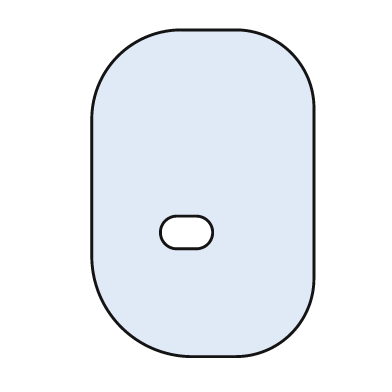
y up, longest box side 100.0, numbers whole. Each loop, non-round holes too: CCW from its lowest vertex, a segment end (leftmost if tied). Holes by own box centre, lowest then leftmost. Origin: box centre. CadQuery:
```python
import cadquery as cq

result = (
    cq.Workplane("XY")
    .moveTo(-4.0, -50.0)
    .lineTo(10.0, -50.0)
    .threePointArc((27.0, -43.0), (34.0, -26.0))
    .lineTo(34.0, 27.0)
    .threePointArc((27.0, 43.0), (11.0, 50.0))
    .lineTo(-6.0, 50.0)
    .threePointArc((-26.0, 42.0), (-34.0, 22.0))
    .lineTo(-34.0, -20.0)
    .threePointArc((-25.0, -41.0), (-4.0, -50.0))
    .close()
    .moveTo(-8.0, -17.0)
    .lineTo(-2.0, -17.0)
    .threePointArc((3.0, -12.0), (-2.0, -7.0))
    .lineTo(-8.0, -7.0)
    .threePointArc((-13.0, -12.0), (-8.0, -17.0))
    .close()
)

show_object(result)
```